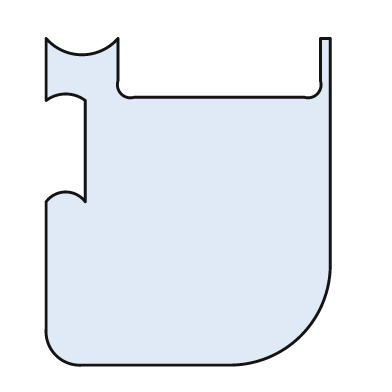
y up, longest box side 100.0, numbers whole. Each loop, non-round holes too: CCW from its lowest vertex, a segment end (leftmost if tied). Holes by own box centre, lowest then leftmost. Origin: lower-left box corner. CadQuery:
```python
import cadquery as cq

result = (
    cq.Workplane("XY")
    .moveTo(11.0, 0.0)
    .lineTo(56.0, 0.0)
    .threePointArc((78.0, 9.0), (87.0, 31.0))
    .lineTo(87.0, 100.0)
    .lineTo(84.0, 100.0)
    .lineTo(84.0, 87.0)
    .threePointArc((83.0, 83.0), (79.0, 82.0))
    .lineTo(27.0, 82.0)
    .threePointArc((23.0, 83.0), (22.0, 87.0))
    .lineTo(22.0, 100.0)
    .threePointArc((11.0, 95.0), (0.0, 100.0))
    .lineTo(0.0, 81.0)
    .threePointArc((6.0, 83.0), (12.0, 81.0))
    .lineTo(12.0, 50.0)
    .threePointArc((6.0, 53.0), (0.0, 50.0))
    .lineTo(0.0, 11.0)
    .threePointArc((3.0, 3.0), (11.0, 0.0))
    .close()
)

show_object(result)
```